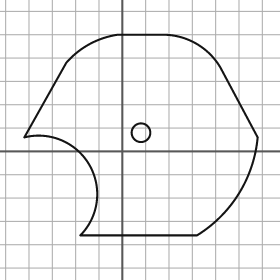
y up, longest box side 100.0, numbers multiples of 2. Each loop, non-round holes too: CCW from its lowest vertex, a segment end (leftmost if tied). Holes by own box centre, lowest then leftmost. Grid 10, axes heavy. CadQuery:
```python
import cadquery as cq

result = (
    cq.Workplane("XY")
    .moveTo(-18.0, -36.0)
    .lineTo(32.0, -36.0)
    .threePointArc((50.0, -18.0), (58.0, 6.0))
    .lineTo(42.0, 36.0)
    .threePointArc((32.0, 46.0), (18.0, 50.0))
    .lineTo(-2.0, 50.0)
    .threePointArc((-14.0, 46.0), (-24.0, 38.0))
    .lineTo(-42.0, 6.0)
    .threePointArc((-14.0, -6.0), (-18.0, -36.0))
    .close()
    .moveTo(8.0, 8.0)
    .circle(4.0)
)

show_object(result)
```